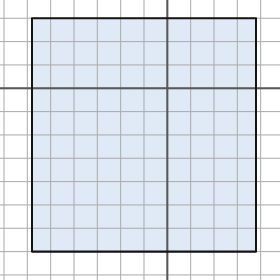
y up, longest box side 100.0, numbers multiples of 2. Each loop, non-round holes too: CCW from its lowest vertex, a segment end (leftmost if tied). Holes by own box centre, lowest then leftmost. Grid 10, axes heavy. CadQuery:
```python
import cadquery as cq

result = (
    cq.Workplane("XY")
    .moveTo(-58.0, -70.0)
    .lineTo(38.0, -70.0)
    .lineTo(38.0, 30.0)
    .lineTo(-58.0, 30.0)
    .close()
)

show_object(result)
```